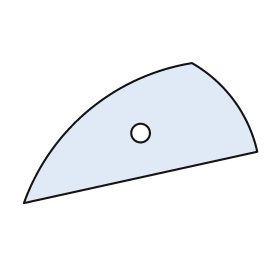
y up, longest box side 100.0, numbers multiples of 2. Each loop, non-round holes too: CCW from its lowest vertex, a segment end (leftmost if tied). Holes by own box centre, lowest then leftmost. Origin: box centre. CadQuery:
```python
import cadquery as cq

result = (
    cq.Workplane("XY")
    .moveTo(-50.0, -30.0)
    .lineTo(50.0, -8.0)
    .threePointArc((40.0, 14.0), (22.0, 30.0))
    .threePointArc((-22.0, 10.0), (-50.0, -30.0))
    .close()
    .moveTo(0.0, 0.0)
    .circle(4.0)
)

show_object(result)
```